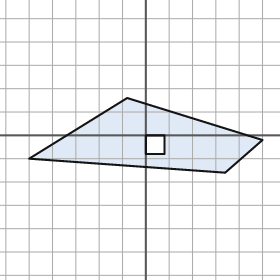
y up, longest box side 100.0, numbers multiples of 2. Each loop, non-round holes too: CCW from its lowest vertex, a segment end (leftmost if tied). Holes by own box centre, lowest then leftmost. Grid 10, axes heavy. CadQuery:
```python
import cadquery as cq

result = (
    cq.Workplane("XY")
    .moveTo(34.0, -16.0)
    .lineTo(50.0, -2.0)
    .lineTo(-8.0, 16.0)
    .lineTo(-50.0, -10.0)
    .close()
    .moveTo(0.0, -8.0)
    .lineTo(8.0, -8.0)
    .lineTo(8.0, 0.0)
    .lineTo(0.0, 0.0)
    .close()
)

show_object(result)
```